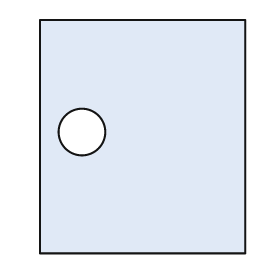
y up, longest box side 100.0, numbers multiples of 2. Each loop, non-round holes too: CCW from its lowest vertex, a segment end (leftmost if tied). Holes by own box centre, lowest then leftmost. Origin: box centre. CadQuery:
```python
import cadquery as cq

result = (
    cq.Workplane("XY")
    .moveTo(-44.0, -50.0)
    .lineTo(44.0, -50.0)
    .lineTo(44.0, 50.0)
    .lineTo(-44.0, 50.0)
    .close()
    .moveTo(-26.0, 2.0)
    .circle(10.0)
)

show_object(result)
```